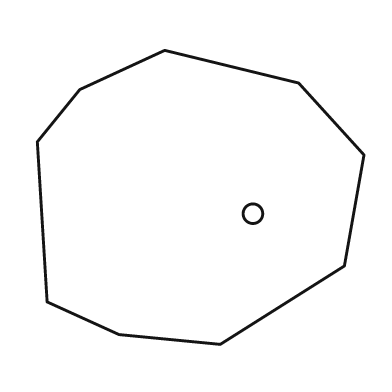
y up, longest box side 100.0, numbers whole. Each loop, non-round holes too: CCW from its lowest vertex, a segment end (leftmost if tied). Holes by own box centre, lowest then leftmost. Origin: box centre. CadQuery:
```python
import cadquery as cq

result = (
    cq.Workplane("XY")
    .moveTo(6.0, -45.0)
    .lineTo(44.0, -21.0)
    .lineTo(50.0, 13.0)
    .lineTo(30.0, 35.0)
    .lineTo(-11.0, 45.0)
    .lineTo(-37.0, 33.0)
    .lineTo(-50.0, 17.0)
    .lineTo(-47.0, -32.0)
    .lineTo(-25.0, -42.0)
    .close()
    .moveTo(16.0, -5.0)
    .circle(3.0)
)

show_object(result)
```